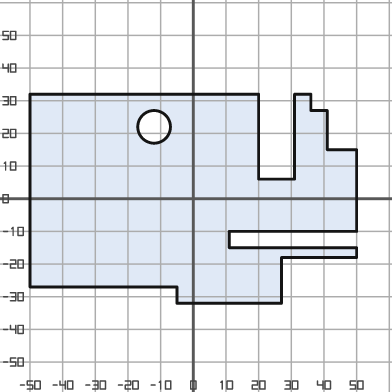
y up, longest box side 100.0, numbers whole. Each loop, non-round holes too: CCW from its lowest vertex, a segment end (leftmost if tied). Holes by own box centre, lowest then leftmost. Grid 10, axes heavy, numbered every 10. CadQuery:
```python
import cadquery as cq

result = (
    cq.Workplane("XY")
    .moveTo(-5.0, -32.0)
    .lineTo(27.0, -32.0)
    .lineTo(27.0, -18.0)
    .lineTo(50.0, -18.0)
    .lineTo(50.0, -15.0)
    .lineTo(11.0, -15.0)
    .lineTo(11.0, -10.0)
    .lineTo(50.0, -10.0)
    .lineTo(50.0, 15.0)
    .lineTo(41.0, 15.0)
    .lineTo(41.0, 27.0)
    .lineTo(36.0, 27.0)
    .lineTo(36.0, 32.0)
    .lineTo(31.0, 32.0)
    .lineTo(31.0, 6.0)
    .lineTo(20.0, 6.0)
    .lineTo(20.0, 32.0)
    .lineTo(-50.0, 32.0)
    .lineTo(-50.0, -27.0)
    .lineTo(-5.0, -27.0)
    .close()
    .moveTo(-12.0, 22.0)
    .circle(5.0)
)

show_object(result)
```